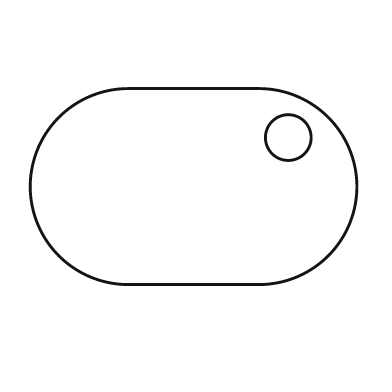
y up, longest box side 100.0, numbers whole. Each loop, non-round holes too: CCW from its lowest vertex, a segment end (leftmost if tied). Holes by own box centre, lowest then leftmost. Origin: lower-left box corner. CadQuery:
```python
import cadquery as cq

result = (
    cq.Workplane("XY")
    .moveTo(30.0, 0.0)
    .lineTo(70.0, 0.0)
    .threePointArc((100.0, 30.0), (70.0, 60.0))
    .lineTo(30.0, 60.0)
    .threePointArc((0.0, 30.0), (30.0, 0.0))
    .close()
    .moveTo(79.0, 45.0)
    .circle(7.0)
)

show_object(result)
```